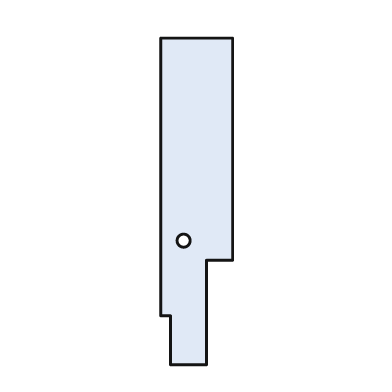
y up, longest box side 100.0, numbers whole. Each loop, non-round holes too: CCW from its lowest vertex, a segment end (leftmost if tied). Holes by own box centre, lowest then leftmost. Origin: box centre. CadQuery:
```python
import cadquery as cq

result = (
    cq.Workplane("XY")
    .moveTo(-8.0, -50.0)
    .lineTo(3.0, -50.0)
    .lineTo(3.0, -18.0)
    .lineTo(11.0, -18.0)
    .lineTo(11.0, 50.0)
    .lineTo(-11.0, 50.0)
    .lineTo(-11.0, -35.0)
    .lineTo(-8.0, -35.0)
    .close()
    .moveTo(-4.0, -12.0)
    .circle(2.0)
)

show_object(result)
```